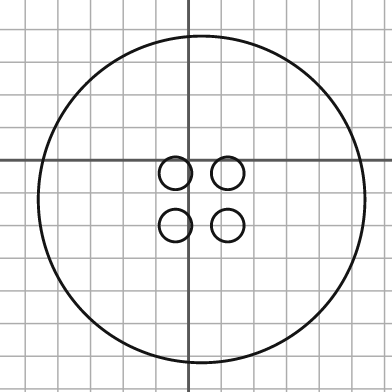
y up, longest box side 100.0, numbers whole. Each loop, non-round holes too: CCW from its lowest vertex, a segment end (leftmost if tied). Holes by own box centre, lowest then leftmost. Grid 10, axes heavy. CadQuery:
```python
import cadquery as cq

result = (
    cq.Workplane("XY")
    .moveTo(4.0, -12.0)
    .circle(50.0)
    .moveTo(-4.0, -20.0)
    .circle(5.0)
    .moveTo(12.0, -20.0)
    .circle(5.0)
    .moveTo(-4.0, -4.0)
    .circle(5.0)
    .moveTo(12.0, -4.0)
    .circle(5.0)
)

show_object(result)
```